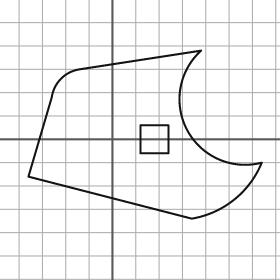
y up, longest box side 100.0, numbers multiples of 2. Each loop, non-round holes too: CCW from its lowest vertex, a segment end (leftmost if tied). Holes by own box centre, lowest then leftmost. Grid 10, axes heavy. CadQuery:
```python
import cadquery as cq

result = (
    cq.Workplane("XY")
    .moveTo(34.0, -34.0)
    .threePointArc((52.0, -26.0), (64.0, -10.0))
    .threePointArc((32.0, 4.0), (38.0, 38.0))
    .lineTo(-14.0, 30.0)
    .threePointArc((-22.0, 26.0), (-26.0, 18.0))
    .lineTo(-36.0, -16.0)
    .close()
    .moveTo(12.0, -6.0)
    .lineTo(24.0, -6.0)
    .lineTo(24.0, 6.0)
    .lineTo(12.0, 6.0)
    .close()
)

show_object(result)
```